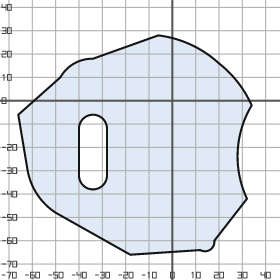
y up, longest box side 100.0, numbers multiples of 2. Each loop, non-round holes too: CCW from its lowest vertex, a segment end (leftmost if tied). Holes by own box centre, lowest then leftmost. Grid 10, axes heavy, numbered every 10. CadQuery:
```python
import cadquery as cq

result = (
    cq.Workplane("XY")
    .moveTo(-18.0, -66.0)
    .lineTo(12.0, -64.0)
    .threePointArc((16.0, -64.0), (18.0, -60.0))
    .lineTo(32.0, -42.0)
    .threePointArc((28.0, -22.0), (34.0, -2.0))
    .threePointArc((28.0, 8.0), (20.0, 16.0))
    .threePointArc((8.0, 24.0), (-6.0, 28.0))
    .lineTo(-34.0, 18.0)
    .threePointArc((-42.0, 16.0), (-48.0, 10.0))
    .lineTo(-66.0, -6.0)
    .lineTo(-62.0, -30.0)
    .threePointArc((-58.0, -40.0), (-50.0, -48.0))
    .close()
    .moveTo(-40.0, -32.0)
    .threePointArc((-34.0, -38.0), (-28.0, -32.0))
    .lineTo(-28.0, -12.0)
    .threePointArc((-34.0, -6.0), (-40.0, -12.0))
    .close()
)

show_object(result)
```